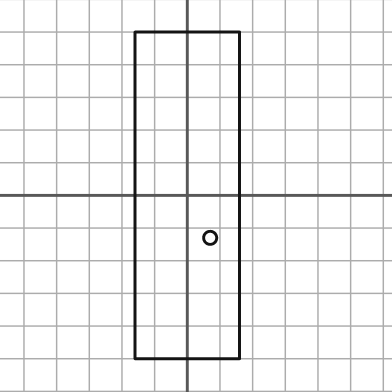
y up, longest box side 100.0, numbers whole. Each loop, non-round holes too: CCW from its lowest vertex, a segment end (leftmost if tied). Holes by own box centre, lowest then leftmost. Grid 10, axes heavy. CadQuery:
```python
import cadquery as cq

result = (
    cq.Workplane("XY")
    .moveTo(-16.0, -50.0)
    .lineTo(16.0, -50.0)
    .lineTo(16.0, 50.0)
    .lineTo(-16.0, 50.0)
    .close()
    .moveTo(7.0, -13.0)
    .circle(2.0)
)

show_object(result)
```